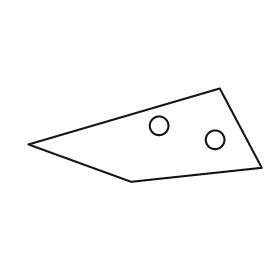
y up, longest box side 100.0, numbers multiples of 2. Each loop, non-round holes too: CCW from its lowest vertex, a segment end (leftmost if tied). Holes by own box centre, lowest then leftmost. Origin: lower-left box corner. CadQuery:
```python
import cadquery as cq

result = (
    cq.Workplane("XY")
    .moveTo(44.0, 0.0)
    .lineTo(100.0, 6.0)
    .lineTo(82.0, 40.0)
    .lineTo(0.0, 16.0)
    .close()
    .moveTo(80.0, 18.0)
    .circle(4.0)
    .moveTo(56.0, 24.0)
    .circle(4.0)
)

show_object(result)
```